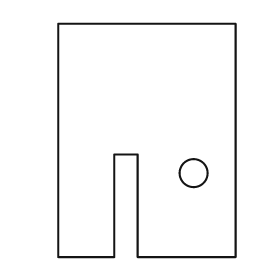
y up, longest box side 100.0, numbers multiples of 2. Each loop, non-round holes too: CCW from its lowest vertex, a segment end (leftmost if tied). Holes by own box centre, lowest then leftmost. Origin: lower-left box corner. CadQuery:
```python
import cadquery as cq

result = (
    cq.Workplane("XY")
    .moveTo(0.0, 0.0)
    .lineTo(24.0, 0.0)
    .lineTo(24.0, 44.0)
    .lineTo(34.0, 44.0)
    .lineTo(34.0, 0.0)
    .lineTo(76.0, 0.0)
    .lineTo(76.0, 100.0)
    .lineTo(0.0, 100.0)
    .close()
    .moveTo(58.0, 36.0)
    .circle(6.0)
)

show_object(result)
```